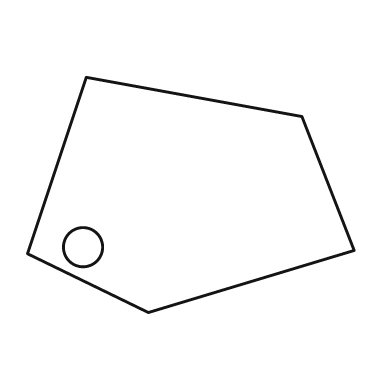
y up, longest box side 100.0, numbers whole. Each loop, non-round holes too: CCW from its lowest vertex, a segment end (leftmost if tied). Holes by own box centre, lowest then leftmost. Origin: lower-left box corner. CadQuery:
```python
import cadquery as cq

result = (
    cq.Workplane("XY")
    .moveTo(37.0, 0.0)
    .lineTo(100.0, 19.0)
    .lineTo(84.0, 60.0)
    .lineTo(18.0, 72.0)
    .lineTo(0.0, 18.0)
    .close()
    .moveTo(17.0, 20.0)
    .circle(6.0)
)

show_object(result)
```